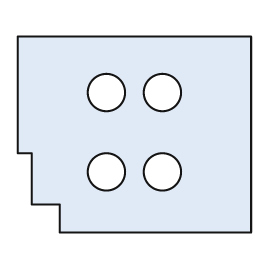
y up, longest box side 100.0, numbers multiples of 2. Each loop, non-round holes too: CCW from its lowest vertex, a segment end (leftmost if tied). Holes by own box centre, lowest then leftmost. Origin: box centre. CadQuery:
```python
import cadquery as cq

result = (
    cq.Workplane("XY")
    .moveTo(-32.0, -42.0)
    .lineTo(50.0, -42.0)
    .lineTo(50.0, 42.0)
    .lineTo(-50.0, 42.0)
    .lineTo(-50.0, -8.0)
    .lineTo(-44.0, -8.0)
    .lineTo(-44.0, -30.0)
    .lineTo(-32.0, -30.0)
    .close()
    .moveTo(-12.0, -16.0)
    .circle(8.0)
    .moveTo(12.0, -16.0)
    .circle(8.0)
    .moveTo(-12.0, 18.0)
    .circle(8.0)
    .moveTo(12.0, 18.0)
    .circle(8.0)
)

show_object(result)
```